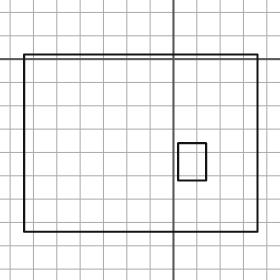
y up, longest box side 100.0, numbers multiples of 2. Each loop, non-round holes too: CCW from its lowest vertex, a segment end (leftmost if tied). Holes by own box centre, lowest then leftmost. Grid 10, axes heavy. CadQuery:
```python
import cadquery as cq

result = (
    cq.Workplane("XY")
    .moveTo(-64.0, -74.0)
    .lineTo(36.0, -74.0)
    .lineTo(36.0, 2.0)
    .lineTo(-64.0, 2.0)
    .close()
    .moveTo(2.0, -52.0)
    .lineTo(14.0, -52.0)
    .lineTo(14.0, -36.0)
    .lineTo(2.0, -36.0)
    .close()
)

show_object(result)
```